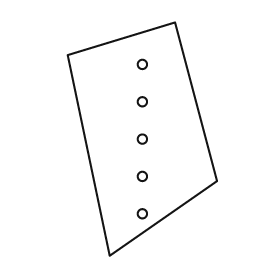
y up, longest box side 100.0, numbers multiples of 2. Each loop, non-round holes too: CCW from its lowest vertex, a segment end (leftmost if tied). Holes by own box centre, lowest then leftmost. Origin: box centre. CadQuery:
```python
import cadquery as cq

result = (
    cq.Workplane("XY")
    .moveTo(-14.0, -50.0)
    .lineTo(32.0, -18.0)
    .lineTo(14.0, 50.0)
    .lineTo(-32.0, 36.0)
    .close()
    .moveTo(0.0, -32.0)
    .circle(2.0)
    .moveTo(0.0, -16.0)
    .circle(2.0)
    .moveTo(0.0, 0.0)
    .circle(2.0)
    .moveTo(0.0, 16.0)
    .circle(2.0)
    .moveTo(0.0, 32.0)
    .circle(2.0)
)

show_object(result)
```